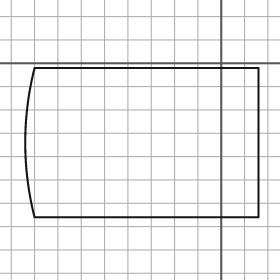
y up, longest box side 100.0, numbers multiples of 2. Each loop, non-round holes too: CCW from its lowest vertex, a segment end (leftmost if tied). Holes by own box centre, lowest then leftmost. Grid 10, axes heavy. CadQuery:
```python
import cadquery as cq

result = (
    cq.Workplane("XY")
    .moveTo(-80.0, -66.0)
    .lineTo(16.0, -66.0)
    .lineTo(16.0, -2.0)
    .lineTo(-80.0, -2.0)
    .threePointArc((-84.0, -34.0), (-80.0, -66.0))
    .close()
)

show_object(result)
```